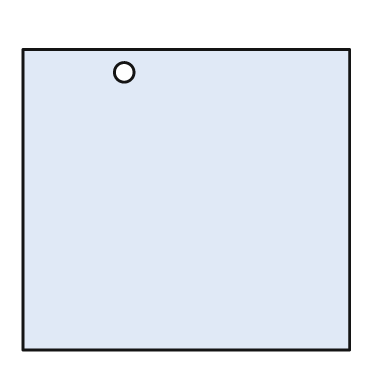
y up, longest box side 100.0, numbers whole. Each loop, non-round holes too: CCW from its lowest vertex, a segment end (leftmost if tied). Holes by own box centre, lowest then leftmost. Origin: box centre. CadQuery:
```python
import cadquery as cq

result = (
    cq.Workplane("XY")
    .moveTo(-50.0, -46.0)
    .lineTo(50.0, -46.0)
    .lineTo(50.0, 46.0)
    .lineTo(-50.0, 46.0)
    .close()
    .moveTo(-19.0, 39.0)
    .circle(3.0)
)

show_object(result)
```